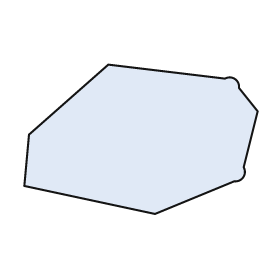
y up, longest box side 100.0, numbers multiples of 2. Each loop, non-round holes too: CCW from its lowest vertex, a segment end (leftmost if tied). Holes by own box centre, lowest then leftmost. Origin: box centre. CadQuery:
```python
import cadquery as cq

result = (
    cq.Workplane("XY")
    .moveTo(6.0, -32.0)
    .lineTo(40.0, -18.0)
    .threePointArc((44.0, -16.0), (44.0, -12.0))
    .lineTo(50.0, 12.0)
    .lineTo(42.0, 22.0)
    .threePointArc((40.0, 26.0), (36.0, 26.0))
    .lineTo(-14.0, 32.0)
    .lineTo(-48.0, 2.0)
    .lineTo(-50.0, -20.0)
    .close()
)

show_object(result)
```